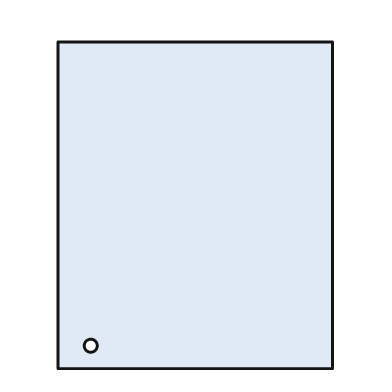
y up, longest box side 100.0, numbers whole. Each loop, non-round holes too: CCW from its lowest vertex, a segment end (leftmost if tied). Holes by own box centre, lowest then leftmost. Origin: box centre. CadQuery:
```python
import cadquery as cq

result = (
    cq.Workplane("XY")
    .moveTo(-42.0, -50.0)
    .lineTo(42.0, -50.0)
    .lineTo(42.0, 50.0)
    .lineTo(-42.0, 50.0)
    .close()
    .moveTo(-32.0, -43.0)
    .circle(2.0)
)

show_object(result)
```